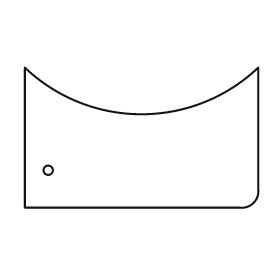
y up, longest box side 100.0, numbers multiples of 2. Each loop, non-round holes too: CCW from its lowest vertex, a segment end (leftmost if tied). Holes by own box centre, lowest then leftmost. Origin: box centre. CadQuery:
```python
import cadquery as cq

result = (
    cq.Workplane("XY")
    .moveTo(-50.0, -30.0)
    .lineTo(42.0, -30.0)
    .threePointArc((48.0, -28.0), (50.0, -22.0))
    .lineTo(50.0, 30.0)
    .threePointArc((0.0, 10.0), (-50.0, 30.0))
    .close()
    .moveTo(-40.0, -14.0)
    .circle(2.0)
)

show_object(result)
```